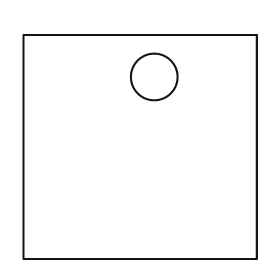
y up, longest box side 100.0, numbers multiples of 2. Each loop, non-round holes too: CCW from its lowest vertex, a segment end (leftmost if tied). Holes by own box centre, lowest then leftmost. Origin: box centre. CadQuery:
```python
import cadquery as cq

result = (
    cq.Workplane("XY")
    .moveTo(-50.0, -48.0)
    .lineTo(50.0, -48.0)
    .lineTo(50.0, 48.0)
    .lineTo(-50.0, 48.0)
    .close()
    .moveTo(6.0, 30.0)
    .circle(10.0)
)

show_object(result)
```